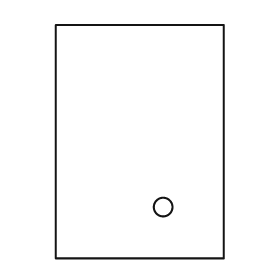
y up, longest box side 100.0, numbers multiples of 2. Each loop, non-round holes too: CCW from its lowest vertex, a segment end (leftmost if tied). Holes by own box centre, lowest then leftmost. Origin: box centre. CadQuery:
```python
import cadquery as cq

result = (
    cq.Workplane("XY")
    .moveTo(-36.0, -50.0)
    .lineTo(36.0, -50.0)
    .lineTo(36.0, 50.0)
    .lineTo(-36.0, 50.0)
    .close()
    .moveTo(10.0, -28.0)
    .circle(4.0)
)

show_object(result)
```